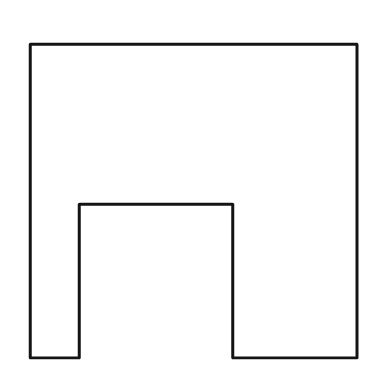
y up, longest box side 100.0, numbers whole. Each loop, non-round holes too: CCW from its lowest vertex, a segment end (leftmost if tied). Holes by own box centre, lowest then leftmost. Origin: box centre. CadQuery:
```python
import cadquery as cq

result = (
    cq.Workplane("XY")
    .moveTo(-50.0, -48.0)
    .lineTo(-35.0, -48.0)
    .lineTo(-35.0, -1.0)
    .lineTo(12.0, -1.0)
    .lineTo(12.0, -48.0)
    .lineTo(50.0, -48.0)
    .lineTo(50.0, 48.0)
    .lineTo(-50.0, 48.0)
    .close()
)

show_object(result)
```